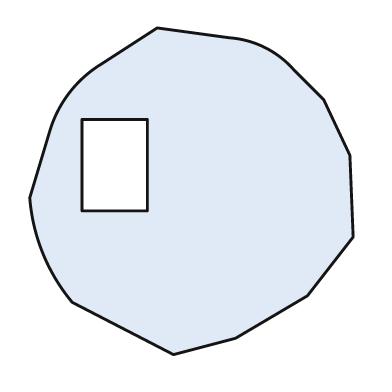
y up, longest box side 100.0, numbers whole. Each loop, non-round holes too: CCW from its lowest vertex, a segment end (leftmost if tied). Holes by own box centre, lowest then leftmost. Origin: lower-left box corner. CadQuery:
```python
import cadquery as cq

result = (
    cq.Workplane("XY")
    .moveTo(44.0, 0.0)
    .lineTo(63.0, 5.0)
    .lineTo(85.0, 18.0)
    .lineTo(99.0, 36.0)
    .lineTo(98.0, 61.0)
    .lineTo(90.0, 78.0)
    .lineTo(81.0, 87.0)
    .threePointArc((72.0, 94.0), (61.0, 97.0))
    .lineTo(39.0, 100.0)
    .lineTo(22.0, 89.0)
    .threePointArc((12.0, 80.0), (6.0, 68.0))
    .lineTo(0.0, 48.0)
    .threePointArc((4.0, 31.0), (13.0, 16.0))
    .close()
    .moveTo(16.0, 44.0)
    .lineTo(36.0, 44.0)
    .lineTo(36.0, 72.0)
    .lineTo(16.0, 72.0)
    .close()
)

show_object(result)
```